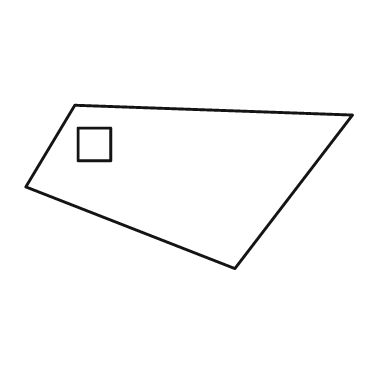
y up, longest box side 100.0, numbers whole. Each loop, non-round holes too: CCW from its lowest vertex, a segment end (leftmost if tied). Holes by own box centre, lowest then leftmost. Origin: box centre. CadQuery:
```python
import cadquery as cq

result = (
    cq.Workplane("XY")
    .moveTo(14.0, -25.0)
    .lineTo(50.0, 22.0)
    .lineTo(-35.0, 25.0)
    .lineTo(-50.0, 0.0)
    .close()
    .moveTo(-34.0, 8.0)
    .lineTo(-24.0, 8.0)
    .lineTo(-24.0, 18.0)
    .lineTo(-34.0, 18.0)
    .close()
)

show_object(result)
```